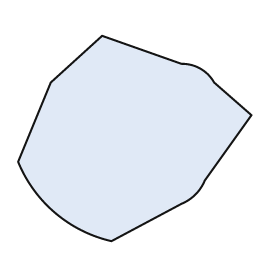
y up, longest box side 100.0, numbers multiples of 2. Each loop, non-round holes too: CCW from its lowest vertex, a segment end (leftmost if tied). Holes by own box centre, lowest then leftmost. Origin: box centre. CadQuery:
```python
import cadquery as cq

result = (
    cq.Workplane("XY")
    .moveTo(-10.0, -44.0)
    .lineTo(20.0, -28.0)
    .threePointArc((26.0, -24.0), (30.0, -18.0))
    .lineTo(50.0, 10.0)
    .lineTo(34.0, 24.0)
    .threePointArc((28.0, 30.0), (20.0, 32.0))
    .lineTo(-14.0, 44.0)
    .lineTo(-36.0, 24.0)
    .lineTo(-50.0, -10.0)
    .threePointArc((-34.0, -32.0), (-10.0, -44.0))
    .close()
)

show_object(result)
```